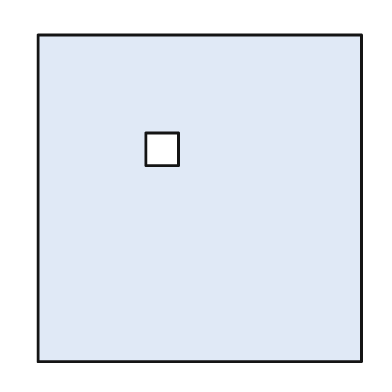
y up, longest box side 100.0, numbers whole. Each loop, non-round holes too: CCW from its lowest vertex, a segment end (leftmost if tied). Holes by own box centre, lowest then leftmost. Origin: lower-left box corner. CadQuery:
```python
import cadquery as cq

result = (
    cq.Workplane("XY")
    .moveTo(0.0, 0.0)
    .lineTo(99.0, 0.0)
    .lineTo(99.0, 100.0)
    .lineTo(0.0, 100.0)
    .close()
    .moveTo(33.0, 60.0)
    .lineTo(43.0, 60.0)
    .lineTo(43.0, 70.0)
    .lineTo(33.0, 70.0)
    .close()
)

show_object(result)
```